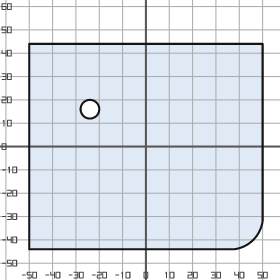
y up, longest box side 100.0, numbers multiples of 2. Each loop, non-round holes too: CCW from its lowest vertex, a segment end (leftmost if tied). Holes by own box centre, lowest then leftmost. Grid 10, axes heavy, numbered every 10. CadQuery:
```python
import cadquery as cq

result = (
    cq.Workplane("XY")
    .moveTo(-50.0, -44.0)
    .lineTo(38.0, -44.0)
    .threePointArc((46.0, -40.0), (50.0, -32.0))
    .lineTo(50.0, 44.0)
    .lineTo(-50.0, 44.0)
    .close()
    .moveTo(-24.0, 16.0)
    .circle(4.0)
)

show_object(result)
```